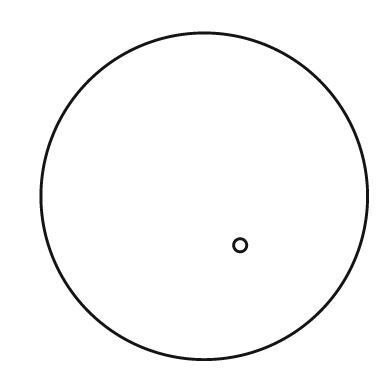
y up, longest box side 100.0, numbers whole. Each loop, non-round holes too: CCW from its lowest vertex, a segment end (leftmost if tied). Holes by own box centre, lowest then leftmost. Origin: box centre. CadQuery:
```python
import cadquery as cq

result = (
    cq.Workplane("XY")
    .moveTo(0.0, 0.0)
    .circle(50.0)
    .moveTo(11.0, -15.0)
    .circle(2.0)
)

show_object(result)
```